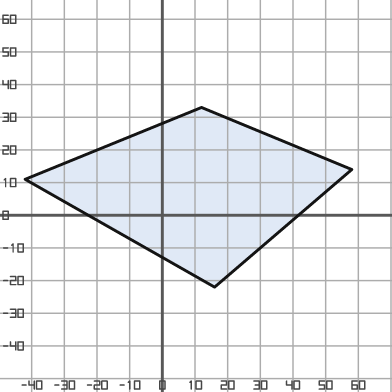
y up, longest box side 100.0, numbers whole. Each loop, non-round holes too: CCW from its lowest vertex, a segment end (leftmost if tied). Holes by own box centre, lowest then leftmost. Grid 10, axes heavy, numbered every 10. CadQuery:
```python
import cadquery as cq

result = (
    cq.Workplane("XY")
    .moveTo(16.0, -22.0)
    .lineTo(58.0, 14.0)
    .lineTo(12.0, 33.0)
    .lineTo(-42.0, 11.0)
    .close()
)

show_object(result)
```